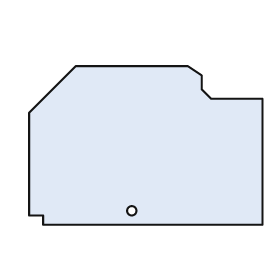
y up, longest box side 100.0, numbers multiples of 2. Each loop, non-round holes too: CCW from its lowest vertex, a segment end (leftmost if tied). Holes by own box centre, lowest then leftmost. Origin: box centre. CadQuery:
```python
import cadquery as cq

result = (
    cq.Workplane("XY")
    .moveTo(-44.0, -34.0)
    .lineTo(50.0, -34.0)
    .lineTo(50.0, 20.0)
    .lineTo(28.0, 20.0)
    .lineTo(24.0, 24.0)
    .lineTo(24.0, 30.0)
    .lineTo(18.0, 34.0)
    .lineTo(-30.0, 34.0)
    .lineTo(-50.0, 14.0)
    .lineTo(-50.0, -30.0)
    .lineTo(-44.0, -30.0)
    .close()
    .moveTo(-6.0, -28.0)
    .circle(2.0)
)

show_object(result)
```